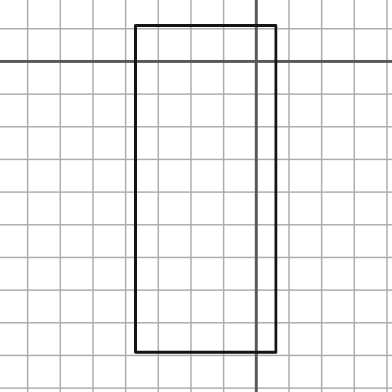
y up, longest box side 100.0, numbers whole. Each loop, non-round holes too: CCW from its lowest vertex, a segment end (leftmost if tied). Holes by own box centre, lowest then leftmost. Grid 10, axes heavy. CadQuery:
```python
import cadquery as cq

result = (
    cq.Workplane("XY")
    .moveTo(-37.0, -89.0)
    .lineTo(6.0, -89.0)
    .lineTo(6.0, 11.0)
    .lineTo(-37.0, 11.0)
    .close()
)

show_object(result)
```